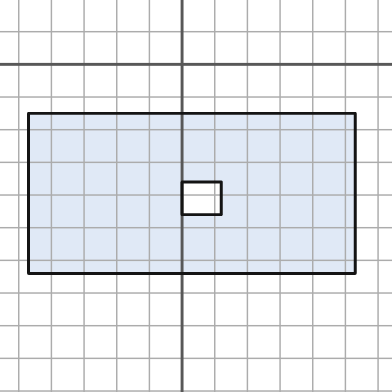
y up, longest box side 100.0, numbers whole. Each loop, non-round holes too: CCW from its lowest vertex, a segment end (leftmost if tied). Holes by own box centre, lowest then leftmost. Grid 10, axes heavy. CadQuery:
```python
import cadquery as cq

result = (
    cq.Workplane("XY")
    .moveTo(-47.0, -64.0)
    .lineTo(53.0, -64.0)
    .lineTo(53.0, -15.0)
    .lineTo(-47.0, -15.0)
    .close()
    .moveTo(0.0, -46.0)
    .lineTo(12.0, -46.0)
    .lineTo(12.0, -36.0)
    .lineTo(0.0, -36.0)
    .close()
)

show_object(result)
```